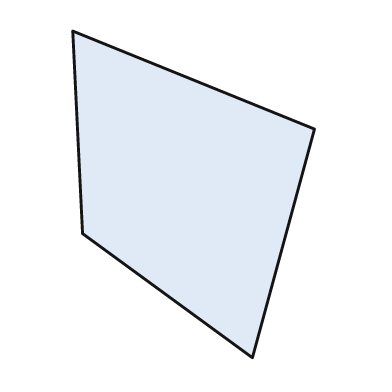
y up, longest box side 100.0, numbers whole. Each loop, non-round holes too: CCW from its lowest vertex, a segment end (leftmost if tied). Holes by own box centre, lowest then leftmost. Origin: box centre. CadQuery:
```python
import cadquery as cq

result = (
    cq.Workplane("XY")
    .moveTo(18.0, -50.0)
    .lineTo(37.0, 20.0)
    .lineTo(-37.0, 50.0)
    .lineTo(-34.0, -12.0)
    .close()
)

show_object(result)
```